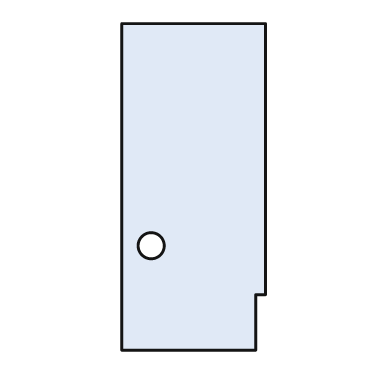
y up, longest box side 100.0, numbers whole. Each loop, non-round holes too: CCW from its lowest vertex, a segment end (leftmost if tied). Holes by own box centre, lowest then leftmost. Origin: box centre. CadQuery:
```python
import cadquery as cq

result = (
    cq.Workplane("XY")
    .moveTo(-22.0, -50.0)
    .lineTo(19.0, -50.0)
    .lineTo(19.0, -33.0)
    .lineTo(22.0, -33.0)
    .lineTo(22.0, 50.0)
    .lineTo(-22.0, 50.0)
    .close()
    .moveTo(-13.0, -18.0)
    .circle(4.0)
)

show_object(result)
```